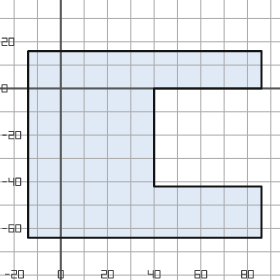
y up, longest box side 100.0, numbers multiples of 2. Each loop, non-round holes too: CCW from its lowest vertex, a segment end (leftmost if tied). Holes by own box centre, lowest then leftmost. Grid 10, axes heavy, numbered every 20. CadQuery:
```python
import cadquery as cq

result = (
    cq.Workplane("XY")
    .moveTo(-14.0, -64.0)
    .lineTo(86.0, -64.0)
    .lineTo(86.0, -42.0)
    .lineTo(40.0, -42.0)
    .lineTo(40.0, 0.0)
    .lineTo(86.0, 0.0)
    .lineTo(86.0, 16.0)
    .lineTo(-14.0, 16.0)
    .close()
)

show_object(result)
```